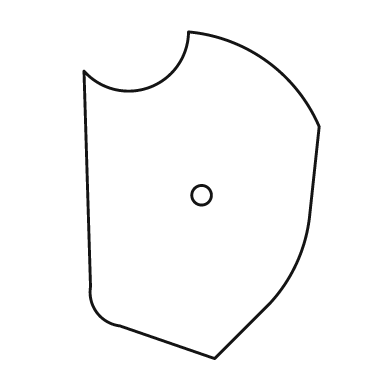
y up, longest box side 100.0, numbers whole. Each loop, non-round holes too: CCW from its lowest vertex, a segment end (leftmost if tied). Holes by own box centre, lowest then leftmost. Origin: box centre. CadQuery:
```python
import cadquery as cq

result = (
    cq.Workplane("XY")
    .moveTo(4.0, -50.0)
    .lineTo(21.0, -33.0)
    .threePointArc((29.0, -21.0), (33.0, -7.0))
    .lineTo(36.0, 21.0)
    .threePointArc((20.0, 41.0), (-4.0, 50.0))
    .threePointArc((-16.0, 33.0), (-36.0, 38.0))
    .lineTo(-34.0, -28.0)
    .threePointArc((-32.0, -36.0), (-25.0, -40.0))
    .close()
    .moveTo(0.0, 0.0)
    .circle(3.0)
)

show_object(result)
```